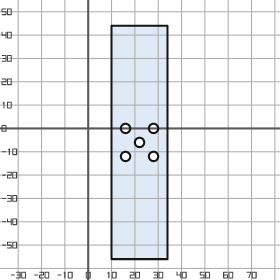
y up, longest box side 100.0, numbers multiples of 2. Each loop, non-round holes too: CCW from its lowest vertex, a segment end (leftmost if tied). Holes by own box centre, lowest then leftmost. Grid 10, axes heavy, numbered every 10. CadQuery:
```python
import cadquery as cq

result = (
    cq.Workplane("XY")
    .moveTo(10.0, -56.0)
    .lineTo(34.0, -56.0)
    .lineTo(34.0, 44.0)
    .lineTo(10.0, 44.0)
    .close()
    .moveTo(16.0, -12.0)
    .circle(2.0)
    .moveTo(28.0, -12.0)
    .circle(2.0)
    .moveTo(22.0, -6.0)
    .circle(2.0)
    .moveTo(16.0, 0.0)
    .circle(2.0)
    .moveTo(28.0, 0.0)
    .circle(2.0)
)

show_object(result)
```